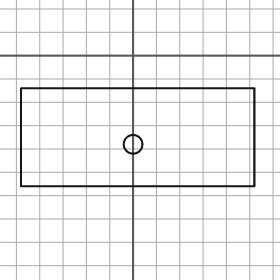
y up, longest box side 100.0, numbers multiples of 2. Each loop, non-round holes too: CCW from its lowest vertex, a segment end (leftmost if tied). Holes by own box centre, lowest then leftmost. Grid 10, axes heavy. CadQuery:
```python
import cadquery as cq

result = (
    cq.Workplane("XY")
    .moveTo(-48.0, -56.0)
    .lineTo(52.0, -56.0)
    .lineTo(52.0, -14.0)
    .lineTo(-48.0, -14.0)
    .close()
    .moveTo(0.0, -38.0)
    .circle(4.0)
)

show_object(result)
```